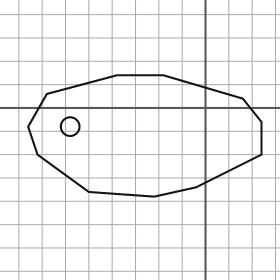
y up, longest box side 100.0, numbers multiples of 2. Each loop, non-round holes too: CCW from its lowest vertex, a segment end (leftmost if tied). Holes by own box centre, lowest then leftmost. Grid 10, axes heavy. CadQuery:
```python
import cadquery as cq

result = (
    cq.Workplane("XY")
    .moveTo(-22.0, -38.0)
    .lineTo(-4.0, -34.0)
    .lineTo(24.0, -20.0)
    .lineTo(24.0, -6.0)
    .lineTo(16.0, 4.0)
    .lineTo(-18.0, 14.0)
    .lineTo(-38.0, 14.0)
    .lineTo(-68.0, 6.0)
    .lineTo(-76.0, -8.0)
    .lineTo(-72.0, -20.0)
    .lineTo(-50.0, -36.0)
    .close()
    .moveTo(-58.0, -8.0)
    .circle(4.0)
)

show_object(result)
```